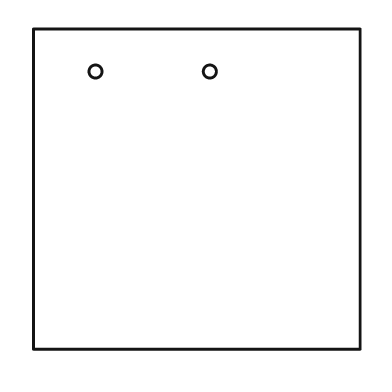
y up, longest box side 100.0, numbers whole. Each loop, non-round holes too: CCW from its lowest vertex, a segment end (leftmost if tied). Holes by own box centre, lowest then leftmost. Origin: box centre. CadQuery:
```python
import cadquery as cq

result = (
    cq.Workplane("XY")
    .moveTo(-50.0, -49.0)
    .lineTo(50.0, -49.0)
    .lineTo(50.0, 49.0)
    .lineTo(-50.0, 49.0)
    .close()
    .moveTo(-31.0, 36.0)
    .circle(2.0)
    .moveTo(4.0, 36.0)
    .circle(2.0)
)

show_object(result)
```